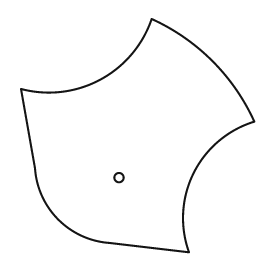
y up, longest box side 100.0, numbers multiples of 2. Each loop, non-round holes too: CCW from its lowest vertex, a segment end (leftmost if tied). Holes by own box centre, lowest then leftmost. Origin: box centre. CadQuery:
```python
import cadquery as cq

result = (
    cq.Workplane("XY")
    .moveTo(22.0, -50.0)
    .threePointArc((24.0, -16.0), (50.0, 6.0))
    .threePointArc((32.0, 32.0), (6.0, 50.0))
    .threePointArc((-16.0, 24.0), (-50.0, 20.0))
    .lineTo(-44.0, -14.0)
    .threePointArc((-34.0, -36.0), (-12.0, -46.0))
    .close()
    .moveTo(-8.0, -18.0)
    .circle(2.0)
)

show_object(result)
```